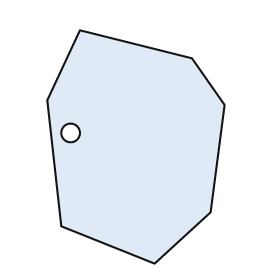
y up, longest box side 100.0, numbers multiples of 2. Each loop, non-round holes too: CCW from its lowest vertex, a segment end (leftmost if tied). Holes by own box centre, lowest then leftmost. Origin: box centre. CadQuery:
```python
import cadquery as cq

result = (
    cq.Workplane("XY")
    .moveTo(8.0, -50.0)
    .lineTo(32.0, -28.0)
    .lineTo(38.0, 18.0)
    .lineTo(24.0, 38.0)
    .lineTo(-24.0, 50.0)
    .lineTo(-38.0, 20.0)
    .lineTo(-32.0, -34.0)
    .close()
    .moveTo(-28.0, 6.0)
    .circle(4.0)
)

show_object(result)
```